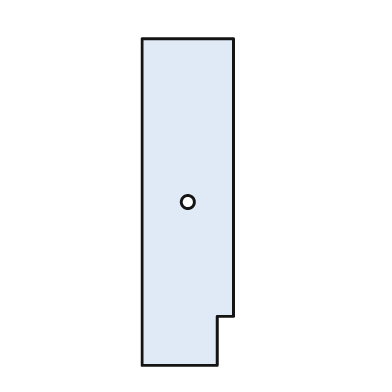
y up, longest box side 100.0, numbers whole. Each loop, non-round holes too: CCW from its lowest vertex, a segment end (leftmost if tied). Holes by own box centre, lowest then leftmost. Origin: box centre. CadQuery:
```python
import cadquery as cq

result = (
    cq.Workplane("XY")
    .moveTo(-14.0, -50.0)
    .lineTo(9.0, -50.0)
    .lineTo(9.0, -35.0)
    .lineTo(14.0, -35.0)
    .lineTo(14.0, 50.0)
    .lineTo(-14.0, 50.0)
    .close()
    .moveTo(0.0, 0.0)
    .circle(2.0)
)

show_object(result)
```